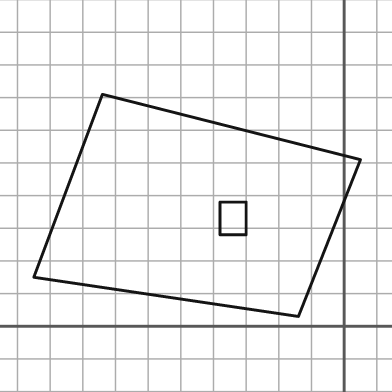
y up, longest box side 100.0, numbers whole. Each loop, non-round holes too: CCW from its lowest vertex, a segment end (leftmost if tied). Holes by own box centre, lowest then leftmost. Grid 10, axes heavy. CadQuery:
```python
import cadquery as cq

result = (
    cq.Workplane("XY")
    .moveTo(-14.0, 3.0)
    .lineTo(5.0, 51.0)
    .lineTo(-74.0, 71.0)
    .lineTo(-95.0, 15.0)
    .close()
    .moveTo(-38.0, 28.0)
    .lineTo(-30.0, 28.0)
    .lineTo(-30.0, 38.0)
    .lineTo(-38.0, 38.0)
    .close()
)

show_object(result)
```